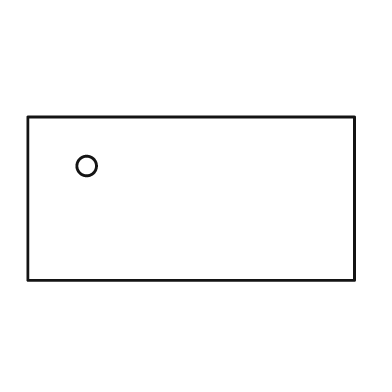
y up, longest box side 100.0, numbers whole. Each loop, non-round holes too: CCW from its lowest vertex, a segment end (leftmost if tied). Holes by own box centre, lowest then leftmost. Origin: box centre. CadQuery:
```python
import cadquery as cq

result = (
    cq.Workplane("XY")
    .moveTo(-50.0, -25.0)
    .lineTo(50.0, -25.0)
    .lineTo(50.0, 25.0)
    .lineTo(-50.0, 25.0)
    .close()
    .moveTo(-32.0, 10.0)
    .circle(3.0)
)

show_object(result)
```